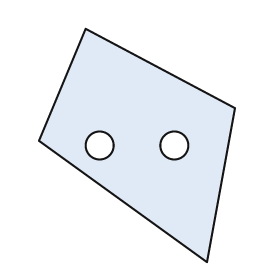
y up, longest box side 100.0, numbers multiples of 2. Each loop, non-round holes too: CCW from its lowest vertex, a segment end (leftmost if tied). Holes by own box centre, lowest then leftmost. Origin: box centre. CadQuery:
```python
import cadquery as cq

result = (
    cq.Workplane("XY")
    .moveTo(30.0, -50.0)
    .lineTo(42.0, 16.0)
    .lineTo(-22.0, 50.0)
    .lineTo(-42.0, 2.0)
    .close()
    .moveTo(-16.0, 0.0)
    .circle(6.0)
    .moveTo(16.0, 0.0)
    .circle(6.0)
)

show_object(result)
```